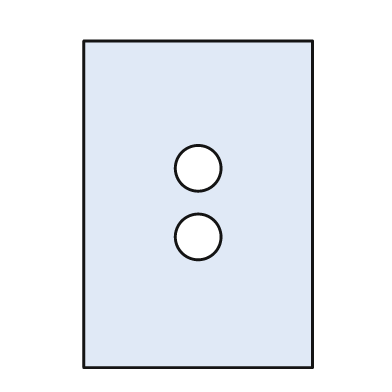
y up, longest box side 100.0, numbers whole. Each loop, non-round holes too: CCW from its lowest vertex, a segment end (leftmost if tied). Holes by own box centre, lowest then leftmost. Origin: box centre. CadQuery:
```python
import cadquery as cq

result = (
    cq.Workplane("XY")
    .moveTo(-35.0, -50.0)
    .lineTo(35.0, -50.0)
    .lineTo(35.0, 50.0)
    .lineTo(-35.0, 50.0)
    .close()
    .moveTo(0.0, -10.0)
    .circle(7.0)
    .moveTo(0.0, 11.0)
    .circle(7.0)
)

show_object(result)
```